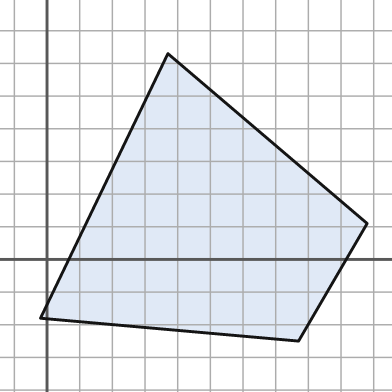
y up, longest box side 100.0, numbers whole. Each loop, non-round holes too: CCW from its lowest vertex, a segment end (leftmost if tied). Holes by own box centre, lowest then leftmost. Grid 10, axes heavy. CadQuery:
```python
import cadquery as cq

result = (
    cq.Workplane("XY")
    .moveTo(77.0, -25.0)
    .lineTo(98.0, 11.0)
    .lineTo(37.0, 63.0)
    .lineTo(-2.0, -18.0)
    .close()
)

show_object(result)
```